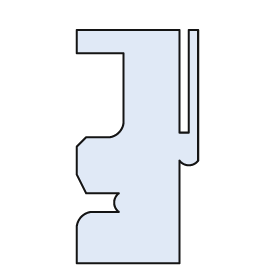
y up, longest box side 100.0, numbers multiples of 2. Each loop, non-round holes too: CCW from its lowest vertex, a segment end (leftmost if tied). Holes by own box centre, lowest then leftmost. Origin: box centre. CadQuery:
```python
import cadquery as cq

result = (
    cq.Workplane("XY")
    .moveTo(-26.0, -50.0)
    .lineTo(18.0, -50.0)
    .lineTo(18.0, -6.0)
    .threePointArc((22.0, -8.0), (26.0, -6.0))
    .lineTo(26.0, 50.0)
    .lineTo(22.0, 50.0)
    .lineTo(22.0, 6.0)
    .lineTo(18.0, 6.0)
    .lineTo(18.0, 50.0)
    .lineTo(-26.0, 50.0)
    .lineTo(-26.0, 40.0)
    .lineTo(-6.0, 40.0)
    .lineTo(-6.0, 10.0)
    .threePointArc((-8.0, 6.0), (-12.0, 4.0))
    .lineTo(-22.0, 4.0)
    .lineTo(-26.0, 0.0)
    .lineTo(-26.0, -12.0)
    .lineTo(-22.0, -20.0)
    .lineTo(-8.0, -20.0)
    .threePointArc((-10.0, -24.0), (-8.0, -28.0))
    .lineTo(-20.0, -28.0)
    .threePointArc((-24.0, -30.0), (-26.0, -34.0))
    .close()
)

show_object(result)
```